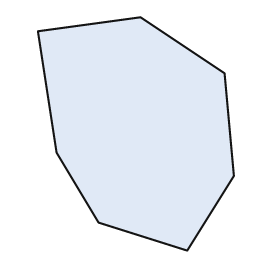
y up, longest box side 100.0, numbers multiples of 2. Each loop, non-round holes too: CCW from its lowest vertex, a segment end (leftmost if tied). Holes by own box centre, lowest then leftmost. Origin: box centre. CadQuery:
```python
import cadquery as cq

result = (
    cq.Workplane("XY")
    .moveTo(22.0, -50.0)
    .lineTo(42.0, -18.0)
    .lineTo(38.0, 26.0)
    .lineTo(2.0, 50.0)
    .lineTo(-42.0, 44.0)
    .lineTo(-34.0, -8.0)
    .lineTo(-16.0, -38.0)
    .close()
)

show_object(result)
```